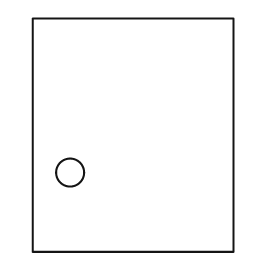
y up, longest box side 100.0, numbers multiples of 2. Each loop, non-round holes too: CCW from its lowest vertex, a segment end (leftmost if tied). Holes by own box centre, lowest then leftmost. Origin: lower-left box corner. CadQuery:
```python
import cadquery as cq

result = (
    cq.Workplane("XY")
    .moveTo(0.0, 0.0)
    .lineTo(86.0, 0.0)
    .lineTo(86.0, 100.0)
    .lineTo(0.0, 100.0)
    .close()
    .moveTo(16.0, 34.0)
    .circle(6.0)
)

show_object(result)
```